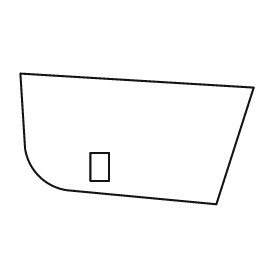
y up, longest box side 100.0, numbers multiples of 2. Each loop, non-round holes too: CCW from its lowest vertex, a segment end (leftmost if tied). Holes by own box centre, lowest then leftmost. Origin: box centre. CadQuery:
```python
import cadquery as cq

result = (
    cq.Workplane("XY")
    .moveTo(34.0, -28.0)
    .lineTo(50.0, 22.0)
    .lineTo(-50.0, 28.0)
    .lineTo(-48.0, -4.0)
    .threePointArc((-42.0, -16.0), (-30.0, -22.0))
    .close()
    .moveTo(-20.0, -18.0)
    .lineTo(-12.0, -18.0)
    .lineTo(-12.0, -6.0)
    .lineTo(-20.0, -6.0)
    .close()
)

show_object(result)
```